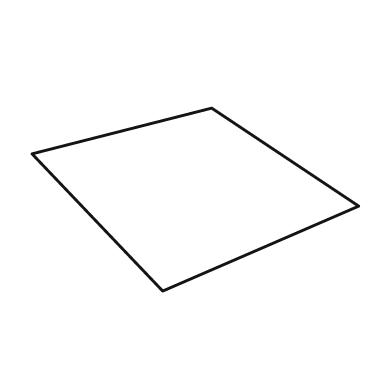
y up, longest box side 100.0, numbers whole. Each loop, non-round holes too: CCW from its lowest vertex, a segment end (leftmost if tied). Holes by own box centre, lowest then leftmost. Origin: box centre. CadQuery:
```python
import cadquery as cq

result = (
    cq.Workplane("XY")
    .moveTo(-10.0, -28.0)
    .lineTo(50.0, -2.0)
    .lineTo(5.0, 28.0)
    .lineTo(-50.0, 14.0)
    .close()
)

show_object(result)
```